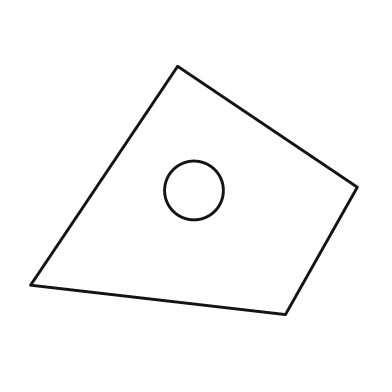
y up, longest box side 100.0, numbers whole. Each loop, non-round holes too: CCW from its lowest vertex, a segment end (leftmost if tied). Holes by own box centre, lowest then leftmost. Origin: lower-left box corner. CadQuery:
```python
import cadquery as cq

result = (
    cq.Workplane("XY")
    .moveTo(78.0, 0.0)
    .lineTo(100.0, 39.0)
    .lineTo(45.0, 76.0)
    .lineTo(0.0, 9.0)
    .close()
    .moveTo(50.0, 38.0)
    .circle(9.0)
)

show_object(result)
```